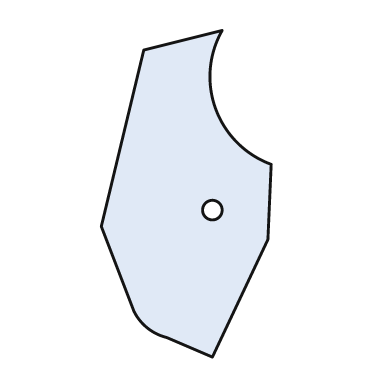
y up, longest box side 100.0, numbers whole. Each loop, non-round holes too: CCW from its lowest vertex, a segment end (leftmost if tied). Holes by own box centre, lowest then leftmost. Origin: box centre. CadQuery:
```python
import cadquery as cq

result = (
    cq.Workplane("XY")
    .moveTo(8.0, -50.0)
    .lineTo(25.0, -14.0)
    .lineTo(26.0, 9.0)
    .threePointArc((9.0, 26.0), (11.0, 50.0))
    .lineTo(-13.0, 44.0)
    .lineTo(-26.0, -10.0)
    .lineTo(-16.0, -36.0)
    .threePointArc((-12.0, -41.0), (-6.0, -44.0))
    .close()
    .moveTo(8.0, -5.0)
    .circle(3.0)
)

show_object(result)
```